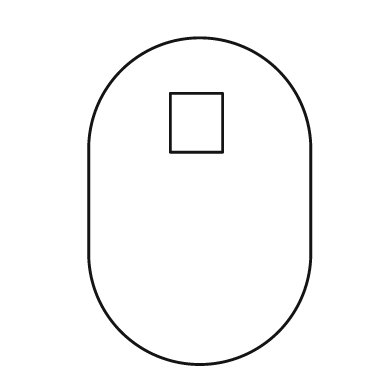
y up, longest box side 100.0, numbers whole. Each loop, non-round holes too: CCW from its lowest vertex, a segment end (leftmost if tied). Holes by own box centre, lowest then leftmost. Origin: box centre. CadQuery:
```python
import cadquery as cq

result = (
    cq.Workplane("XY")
    .moveTo(-34.0, -16.0)
    .threePointArc((0.0, -50.0), (34.0, -16.0))
    .lineTo(34.0, 16.0)
    .threePointArc((0.0, 50.0), (-34.0, 16.0))
    .close()
    .moveTo(-9.0, 15.0)
    .lineTo(7.0, 15.0)
    .lineTo(7.0, 33.0)
    .lineTo(-9.0, 33.0)
    .close()
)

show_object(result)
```